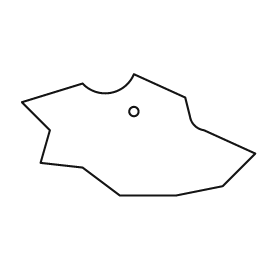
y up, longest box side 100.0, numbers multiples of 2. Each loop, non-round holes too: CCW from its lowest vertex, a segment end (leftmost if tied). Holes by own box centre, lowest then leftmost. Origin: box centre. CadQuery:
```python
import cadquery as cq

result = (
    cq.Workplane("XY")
    .moveTo(-8.0, -26.0)
    .lineTo(16.0, -26.0)
    .lineTo(36.0, -22.0)
    .lineTo(50.0, -8.0)
    .lineTo(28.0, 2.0)
    .threePointArc((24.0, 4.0), (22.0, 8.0))
    .lineTo(20.0, 16.0)
    .lineTo(-2.0, 26.0)
    .threePointArc((-12.0, 18.0), (-24.0, 22.0))
    .lineTo(-50.0, 14.0)
    .lineTo(-38.0, 2.0)
    .lineTo(-42.0, -12.0)
    .lineTo(-24.0, -14.0)
    .close()
    .moveTo(-2.0, 10.0)
    .circle(2.0)
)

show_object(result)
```